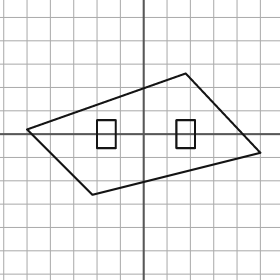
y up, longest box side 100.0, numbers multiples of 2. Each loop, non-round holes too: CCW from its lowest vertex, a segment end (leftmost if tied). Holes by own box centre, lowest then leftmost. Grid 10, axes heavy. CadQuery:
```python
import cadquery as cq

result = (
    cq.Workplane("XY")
    .moveTo(-22.0, -26.0)
    .lineTo(50.0, -8.0)
    .lineTo(18.0, 26.0)
    .lineTo(-50.0, 2.0)
    .close()
    .moveTo(-20.0, -6.0)
    .lineTo(-12.0, -6.0)
    .lineTo(-12.0, 6.0)
    .lineTo(-20.0, 6.0)
    .close()
    .moveTo(14.0, -6.0)
    .lineTo(22.0, -6.0)
    .lineTo(22.0, 6.0)
    .lineTo(14.0, 6.0)
    .close()
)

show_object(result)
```